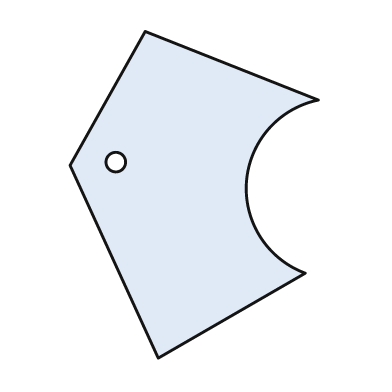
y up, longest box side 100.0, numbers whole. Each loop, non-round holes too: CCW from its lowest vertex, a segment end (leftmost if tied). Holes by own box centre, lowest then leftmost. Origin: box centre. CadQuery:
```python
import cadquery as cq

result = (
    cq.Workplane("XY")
    .moveTo(-11.0, -50.0)
    .lineTo(34.0, -24.0)
    .threePointArc((16.0, 4.0), (38.0, 29.0))
    .lineTo(-15.0, 50.0)
    .lineTo(-38.0, 9.0)
    .close()
    .moveTo(-24.0, 10.0)
    .circle(3.0)
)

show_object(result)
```